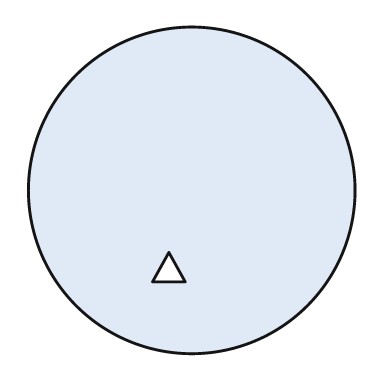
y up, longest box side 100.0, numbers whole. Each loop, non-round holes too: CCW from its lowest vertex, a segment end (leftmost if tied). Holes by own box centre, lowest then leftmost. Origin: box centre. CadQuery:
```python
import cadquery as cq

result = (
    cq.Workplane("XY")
    .moveTo(0.0, 0.0)
    .circle(50.0)
    .moveTo(-12.0, -28.0)
    .lineTo(-2.0, -28.0)
    .lineTo(-7.0, -19.0)
    .close()
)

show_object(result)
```